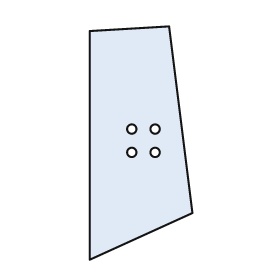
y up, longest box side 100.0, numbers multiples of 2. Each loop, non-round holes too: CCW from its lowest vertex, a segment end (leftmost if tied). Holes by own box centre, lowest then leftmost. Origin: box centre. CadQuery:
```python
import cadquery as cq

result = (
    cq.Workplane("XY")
    .moveTo(-22.0, -50.0)
    .lineTo(22.0, -30.0)
    .lineTo(12.0, 50.0)
    .lineTo(-22.0, 48.0)
    .close()
    .moveTo(-4.0, -4.0)
    .circle(2.0)
    .moveTo(6.0, -4.0)
    .circle(2.0)
    .moveTo(-4.0, 6.0)
    .circle(2.0)
    .moveTo(6.0, 6.0)
    .circle(2.0)
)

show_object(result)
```